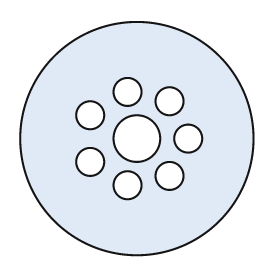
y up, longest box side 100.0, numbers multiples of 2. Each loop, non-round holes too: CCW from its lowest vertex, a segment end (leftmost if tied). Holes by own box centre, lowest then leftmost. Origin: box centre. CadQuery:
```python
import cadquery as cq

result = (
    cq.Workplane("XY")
    .moveTo(0.0, 0.0)
    .circle(50.0)
    .moveTo(-4.0, -20.0)
    .circle(6.0)
    .moveTo(14.0, -16.0)
    .circle(6.0)
    .moveTo(-20.0, -10.0)
    .circle(6.0)
    .moveTo(0.0, 0.0)
    .circle(10.0)
    .moveTo(22.0, 0.0)
    .circle(6.0)
    .moveTo(-20.0, 10.0)
    .circle(6.0)
    .moveTo(14.0, 16.0)
    .circle(6.0)
    .moveTo(-4.0, 20.0)
    .circle(6.0)
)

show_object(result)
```